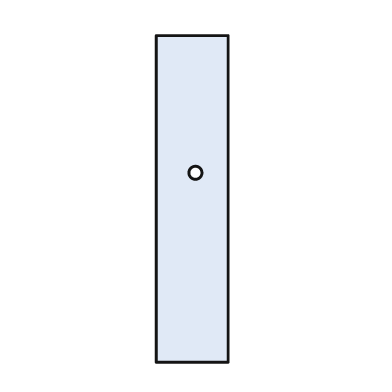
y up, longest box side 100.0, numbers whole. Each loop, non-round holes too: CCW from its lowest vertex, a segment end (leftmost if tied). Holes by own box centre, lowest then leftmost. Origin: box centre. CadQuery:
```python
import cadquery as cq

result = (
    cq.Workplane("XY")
    .moveTo(-11.0, -50.0)
    .lineTo(11.0, -50.0)
    .lineTo(11.0, 50.0)
    .lineTo(-11.0, 50.0)
    .close()
    .moveTo(1.0, 8.0)
    .circle(2.0)
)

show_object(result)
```